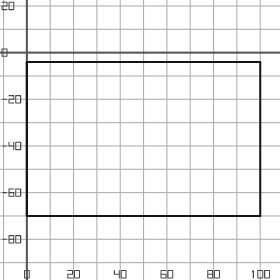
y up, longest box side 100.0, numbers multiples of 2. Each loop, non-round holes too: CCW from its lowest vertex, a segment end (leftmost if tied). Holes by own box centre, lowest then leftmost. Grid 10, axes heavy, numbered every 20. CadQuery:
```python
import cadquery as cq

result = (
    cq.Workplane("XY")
    .moveTo(0.0, -70.0)
    .lineTo(100.0, -70.0)
    .lineTo(100.0, -4.0)
    .lineTo(0.0, -4.0)
    .close()
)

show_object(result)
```